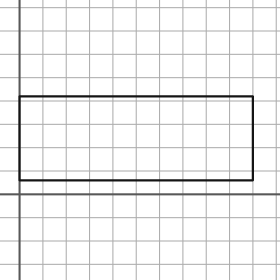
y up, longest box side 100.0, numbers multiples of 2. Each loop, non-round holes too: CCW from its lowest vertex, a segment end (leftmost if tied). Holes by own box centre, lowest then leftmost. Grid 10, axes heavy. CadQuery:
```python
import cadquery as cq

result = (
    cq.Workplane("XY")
    .moveTo(0.0, 6.0)
    .lineTo(100.0, 6.0)
    .lineTo(100.0, 42.0)
    .lineTo(0.0, 42.0)
    .close()
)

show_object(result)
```